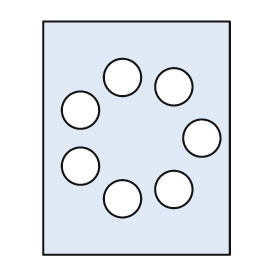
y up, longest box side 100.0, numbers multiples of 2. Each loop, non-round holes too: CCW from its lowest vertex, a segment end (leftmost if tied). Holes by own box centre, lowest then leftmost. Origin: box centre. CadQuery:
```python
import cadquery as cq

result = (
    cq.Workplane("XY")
    .moveTo(-40.0, -50.0)
    .lineTo(40.0, -50.0)
    .lineTo(40.0, 50.0)
    .lineTo(-40.0, 50.0)
    .close()
    .moveTo(-6.0, -26.0)
    .circle(8.0)
    .moveTo(16.0, -22.0)
    .circle(8.0)
    .moveTo(-24.0, -12.0)
    .circle(8.0)
    .moveTo(28.0, 0.0)
    .circle(8.0)
    .moveTo(-24.0, 12.0)
    .circle(8.0)
    .moveTo(16.0, 22.0)
    .circle(8.0)
    .moveTo(-6.0, 26.0)
    .circle(8.0)
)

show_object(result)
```